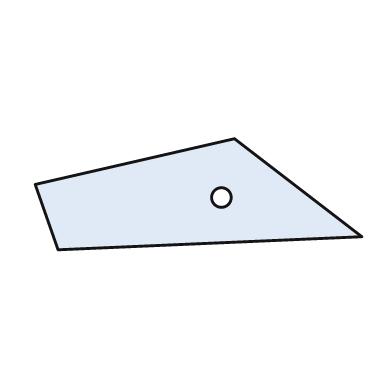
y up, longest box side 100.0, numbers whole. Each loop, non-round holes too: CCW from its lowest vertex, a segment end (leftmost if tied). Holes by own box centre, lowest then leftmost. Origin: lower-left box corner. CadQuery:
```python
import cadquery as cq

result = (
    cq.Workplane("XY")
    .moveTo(7.0, 0.0)
    .lineTo(100.0, 4.0)
    .lineTo(61.0, 34.0)
    .lineTo(0.0, 20.0)
    .close()
    .moveTo(57.0, 16.0)
    .circle(3.0)
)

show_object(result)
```